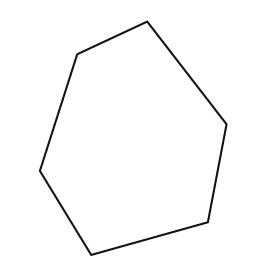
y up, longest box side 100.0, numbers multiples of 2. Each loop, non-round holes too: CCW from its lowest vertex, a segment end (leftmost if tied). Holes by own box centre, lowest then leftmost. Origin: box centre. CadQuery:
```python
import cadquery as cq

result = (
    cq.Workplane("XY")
    .moveTo(-18.0, -50.0)
    .lineTo(32.0, -36.0)
    .lineTo(40.0, 6.0)
    .lineTo(6.0, 50.0)
    .lineTo(-24.0, 36.0)
    .lineTo(-40.0, -14.0)
    .close()
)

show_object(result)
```